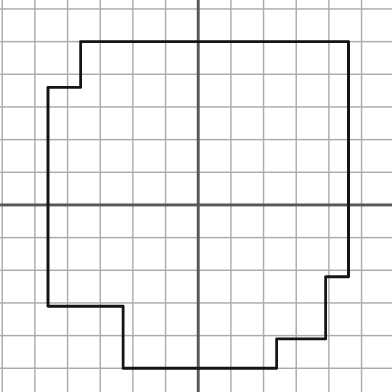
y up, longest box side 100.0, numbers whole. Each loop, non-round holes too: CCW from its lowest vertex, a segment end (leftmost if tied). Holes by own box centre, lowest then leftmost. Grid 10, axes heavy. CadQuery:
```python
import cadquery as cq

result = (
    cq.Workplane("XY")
    .moveTo(-23.0, -50.0)
    .lineTo(24.0, -50.0)
    .lineTo(24.0, -41.0)
    .lineTo(39.0, -41.0)
    .lineTo(39.0, -22.0)
    .lineTo(46.0, -22.0)
    .lineTo(46.0, 50.0)
    .lineTo(-36.0, 50.0)
    .lineTo(-36.0, 36.0)
    .lineTo(-46.0, 36.0)
    .lineTo(-46.0, -31.0)
    .lineTo(-23.0, -31.0)
    .close()
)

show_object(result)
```